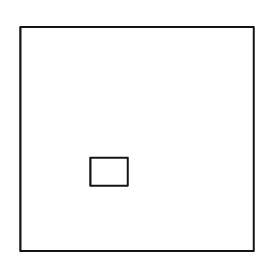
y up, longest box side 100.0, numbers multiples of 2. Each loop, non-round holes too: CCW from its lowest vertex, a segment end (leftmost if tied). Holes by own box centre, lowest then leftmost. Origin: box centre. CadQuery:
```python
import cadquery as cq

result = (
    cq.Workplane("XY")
    .moveTo(-50.0, -48.0)
    .lineTo(50.0, -48.0)
    .lineTo(50.0, 48.0)
    .lineTo(-50.0, 48.0)
    .close()
    .moveTo(-20.0, -20.0)
    .lineTo(-4.0, -20.0)
    .lineTo(-4.0, -8.0)
    .lineTo(-20.0, -8.0)
    .close()
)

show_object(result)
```